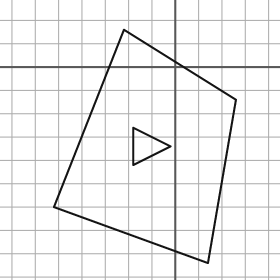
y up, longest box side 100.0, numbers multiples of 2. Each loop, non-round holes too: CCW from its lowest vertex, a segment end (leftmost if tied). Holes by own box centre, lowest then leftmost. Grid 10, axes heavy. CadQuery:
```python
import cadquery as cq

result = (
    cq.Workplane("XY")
    .moveTo(14.0, -84.0)
    .lineTo(26.0, -14.0)
    .lineTo(-22.0, 16.0)
    .lineTo(-52.0, -60.0)
    .close()
    .moveTo(-18.0, -42.0)
    .lineTo(-2.0, -34.0)
    .lineTo(-18.0, -26.0)
    .close()
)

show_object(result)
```